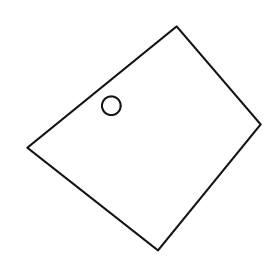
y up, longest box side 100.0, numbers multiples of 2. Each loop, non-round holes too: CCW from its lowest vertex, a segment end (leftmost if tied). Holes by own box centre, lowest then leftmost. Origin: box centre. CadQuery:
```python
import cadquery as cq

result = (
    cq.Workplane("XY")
    .moveTo(6.0, -48.0)
    .lineTo(50.0, 6.0)
    .lineTo(14.0, 48.0)
    .lineTo(-50.0, -4.0)
    .close()
    .moveTo(-14.0, 14.0)
    .circle(4.0)
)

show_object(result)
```